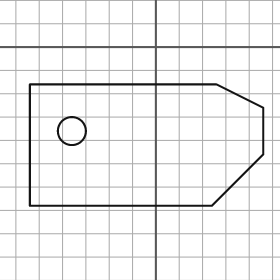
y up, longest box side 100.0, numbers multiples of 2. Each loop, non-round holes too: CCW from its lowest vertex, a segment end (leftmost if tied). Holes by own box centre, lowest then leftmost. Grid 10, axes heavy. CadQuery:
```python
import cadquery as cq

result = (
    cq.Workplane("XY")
    .moveTo(-54.0, -68.0)
    .lineTo(24.0, -68.0)
    .lineTo(46.0, -46.0)
    .lineTo(46.0, -26.0)
    .lineTo(26.0, -16.0)
    .lineTo(-54.0, -16.0)
    .close()
    .moveTo(-36.0, -36.0)
    .circle(6.0)
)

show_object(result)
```